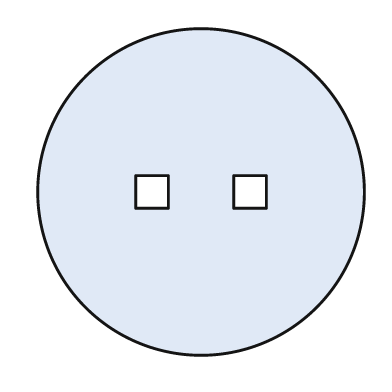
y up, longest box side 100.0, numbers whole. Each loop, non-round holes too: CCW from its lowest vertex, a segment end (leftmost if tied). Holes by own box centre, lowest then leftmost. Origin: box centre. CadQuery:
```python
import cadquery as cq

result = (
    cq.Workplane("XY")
    .moveTo(0.0, 0.0)
    .circle(50.0)
    .moveTo(-20.0, -5.0)
    .lineTo(-10.0, -5.0)
    .lineTo(-10.0, 5.0)
    .lineTo(-20.0, 5.0)
    .close()
    .moveTo(10.0, -5.0)
    .lineTo(20.0, -5.0)
    .lineTo(20.0, 5.0)
    .lineTo(10.0, 5.0)
    .close()
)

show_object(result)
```